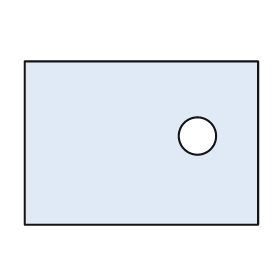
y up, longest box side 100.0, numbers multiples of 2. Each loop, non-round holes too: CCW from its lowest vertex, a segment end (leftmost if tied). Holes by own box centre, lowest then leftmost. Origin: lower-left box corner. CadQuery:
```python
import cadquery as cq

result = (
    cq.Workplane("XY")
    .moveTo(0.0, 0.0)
    .lineTo(100.0, 0.0)
    .lineTo(100.0, 70.0)
    .lineTo(0.0, 70.0)
    .close()
    .moveTo(74.0, 38.0)
    .circle(8.0)
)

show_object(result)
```